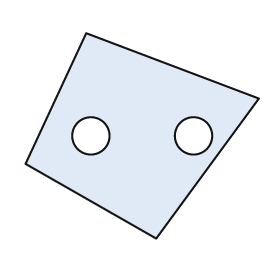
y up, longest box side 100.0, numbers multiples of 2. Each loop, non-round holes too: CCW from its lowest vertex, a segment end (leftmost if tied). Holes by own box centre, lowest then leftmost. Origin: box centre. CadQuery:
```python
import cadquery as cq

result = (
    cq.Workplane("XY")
    .moveTo(6.0, -44.0)
    .lineTo(50.0, 16.0)
    .lineTo(-24.0, 44.0)
    .lineTo(-50.0, -12.0)
    .close()
    .moveTo(-22.0, 0.0)
    .circle(8.0)
    .moveTo(22.0, 0.0)
    .circle(8.0)
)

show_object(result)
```